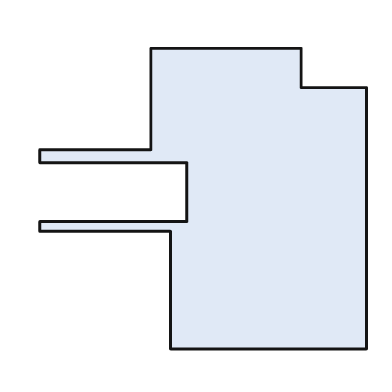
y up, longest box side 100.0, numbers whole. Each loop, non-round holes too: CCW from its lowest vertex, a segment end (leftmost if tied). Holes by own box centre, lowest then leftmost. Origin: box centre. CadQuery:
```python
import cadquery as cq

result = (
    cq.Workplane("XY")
    .moveTo(-10.0, -46.0)
    .lineTo(50.0, -46.0)
    .lineTo(50.0, 34.0)
    .lineTo(30.0, 34.0)
    .lineTo(30.0, 46.0)
    .lineTo(-16.0, 46.0)
    .lineTo(-16.0, 15.0)
    .lineTo(-50.0, 15.0)
    .lineTo(-50.0, 11.0)
    .lineTo(-5.0, 11.0)
    .lineTo(-5.0, -7.0)
    .lineTo(-50.0, -7.0)
    .lineTo(-50.0, -10.0)
    .lineTo(-10.0, -10.0)
    .close()
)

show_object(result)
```